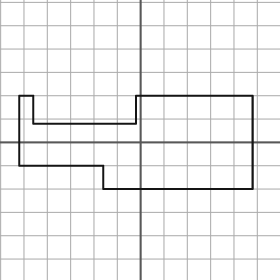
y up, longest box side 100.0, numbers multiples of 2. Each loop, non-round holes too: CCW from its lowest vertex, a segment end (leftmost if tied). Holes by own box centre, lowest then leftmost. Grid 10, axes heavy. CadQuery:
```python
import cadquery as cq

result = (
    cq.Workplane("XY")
    .moveTo(-16.0, -20.0)
    .lineTo(48.0, -20.0)
    .lineTo(48.0, 20.0)
    .lineTo(-2.0, 20.0)
    .lineTo(-2.0, 8.0)
    .lineTo(-46.0, 8.0)
    .lineTo(-46.0, 20.0)
    .lineTo(-52.0, 20.0)
    .lineTo(-52.0, -10.0)
    .lineTo(-16.0, -10.0)
    .close()
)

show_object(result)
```